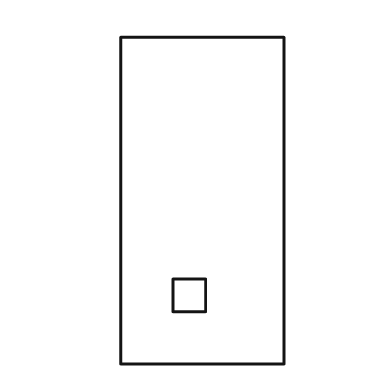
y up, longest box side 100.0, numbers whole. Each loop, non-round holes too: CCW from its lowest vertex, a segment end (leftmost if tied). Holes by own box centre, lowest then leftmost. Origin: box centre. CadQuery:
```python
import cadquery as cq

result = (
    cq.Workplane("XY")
    .moveTo(-25.0, -50.0)
    .lineTo(25.0, -50.0)
    .lineTo(25.0, 50.0)
    .lineTo(-25.0, 50.0)
    .close()
    .moveTo(-9.0, -34.0)
    .lineTo(1.0, -34.0)
    .lineTo(1.0, -24.0)
    .lineTo(-9.0, -24.0)
    .close()
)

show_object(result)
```